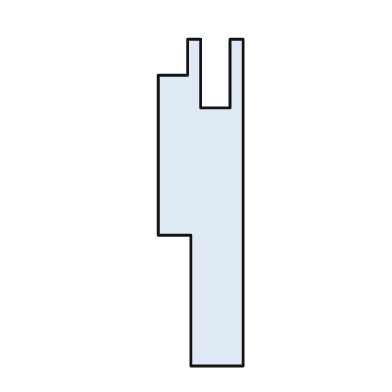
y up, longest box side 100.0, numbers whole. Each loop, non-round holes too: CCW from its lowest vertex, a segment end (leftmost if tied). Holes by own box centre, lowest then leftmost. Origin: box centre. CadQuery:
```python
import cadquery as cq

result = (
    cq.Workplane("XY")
    .moveTo(-3.0, -50.0)
    .lineTo(13.0, -50.0)
    .lineTo(13.0, 50.0)
    .lineTo(9.0, 50.0)
    .lineTo(9.0, 29.0)
    .lineTo(0.0, 29.0)
    .lineTo(0.0, 50.0)
    .lineTo(-4.0, 50.0)
    .lineTo(-4.0, 39.0)
    .lineTo(-13.0, 39.0)
    .lineTo(-13.0, -10.0)
    .lineTo(-3.0, -10.0)
    .close()
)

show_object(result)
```